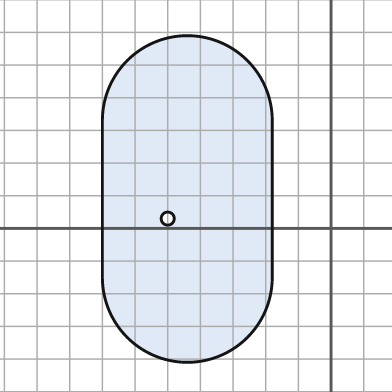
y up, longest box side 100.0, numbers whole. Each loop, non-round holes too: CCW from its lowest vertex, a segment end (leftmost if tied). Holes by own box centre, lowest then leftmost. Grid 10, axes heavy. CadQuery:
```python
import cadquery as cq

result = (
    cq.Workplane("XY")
    .moveTo(-70.0, -15.0)
    .threePointArc((-44.0, -41.0), (-18.0, -15.0))
    .lineTo(-18.0, 33.0)
    .threePointArc((-44.0, 59.0), (-70.0, 33.0))
    .close()
    .moveTo(-50.0, 3.0)
    .circle(2.0)
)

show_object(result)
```